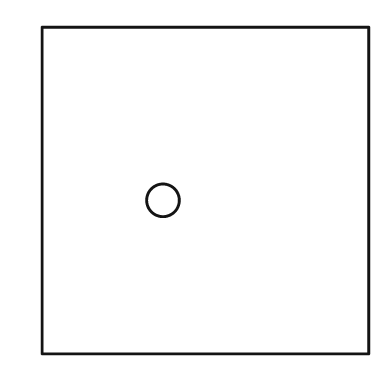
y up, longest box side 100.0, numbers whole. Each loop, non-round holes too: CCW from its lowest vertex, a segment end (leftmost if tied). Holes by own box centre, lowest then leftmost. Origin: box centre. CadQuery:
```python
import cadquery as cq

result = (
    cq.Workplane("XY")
    .moveTo(-50.0, -50.0)
    .lineTo(50.0, -50.0)
    .lineTo(50.0, 50.0)
    .lineTo(-50.0, 50.0)
    .close()
    .moveTo(-13.0, -3.0)
    .circle(5.0)
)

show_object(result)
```